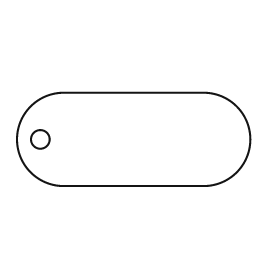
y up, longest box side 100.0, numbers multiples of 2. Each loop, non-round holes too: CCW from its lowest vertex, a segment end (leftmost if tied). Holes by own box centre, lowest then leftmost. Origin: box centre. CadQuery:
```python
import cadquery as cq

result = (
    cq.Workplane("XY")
    .moveTo(-30.0, -20.0)
    .lineTo(30.0, -20.0)
    .threePointArc((50.0, 0.0), (30.0, 20.0))
    .lineTo(-30.0, 20.0)
    .threePointArc((-50.0, 0.0), (-30.0, -20.0))
    .close()
    .moveTo(-40.0, 0.0)
    .circle(4.0)
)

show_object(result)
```